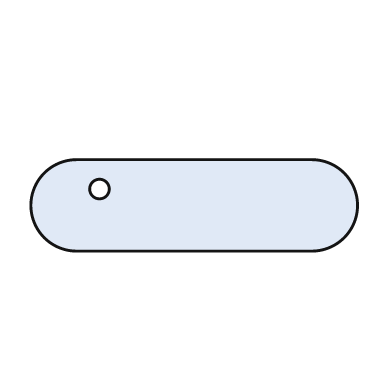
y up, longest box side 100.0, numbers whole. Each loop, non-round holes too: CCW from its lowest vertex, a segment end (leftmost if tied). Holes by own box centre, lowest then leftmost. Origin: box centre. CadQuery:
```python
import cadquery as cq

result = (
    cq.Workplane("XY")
    .moveTo(-36.0, -14.0)
    .lineTo(36.0, -14.0)
    .threePointArc((50.0, 0.0), (36.0, 14.0))
    .lineTo(-36.0, 14.0)
    .threePointArc((-50.0, 0.0), (-36.0, -14.0))
    .close()
    .moveTo(-29.0, 5.0)
    .circle(3.0)
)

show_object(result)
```